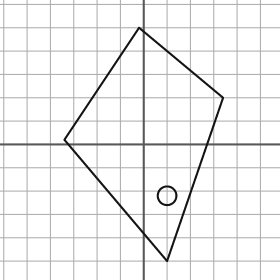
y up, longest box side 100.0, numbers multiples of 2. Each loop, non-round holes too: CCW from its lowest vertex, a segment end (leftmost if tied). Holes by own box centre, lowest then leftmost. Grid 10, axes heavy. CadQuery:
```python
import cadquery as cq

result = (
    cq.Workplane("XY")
    .moveTo(10.0, -50.0)
    .lineTo(34.0, 20.0)
    .lineTo(-2.0, 50.0)
    .lineTo(-34.0, 2.0)
    .close()
    .moveTo(10.0, -22.0)
    .circle(4.0)
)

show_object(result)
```